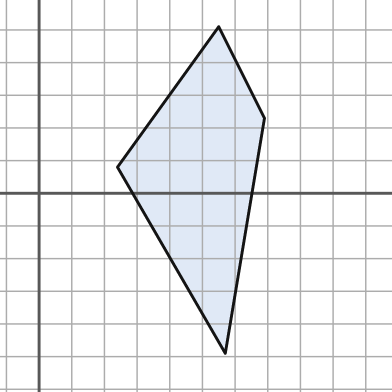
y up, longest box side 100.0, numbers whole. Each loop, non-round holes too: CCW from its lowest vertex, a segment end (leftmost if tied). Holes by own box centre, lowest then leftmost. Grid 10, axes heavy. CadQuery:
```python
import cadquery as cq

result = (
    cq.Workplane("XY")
    .moveTo(57.0, -49.0)
    .lineTo(69.0, 23.0)
    .lineTo(55.0, 51.0)
    .lineTo(24.0, 8.0)
    .close()
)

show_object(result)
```